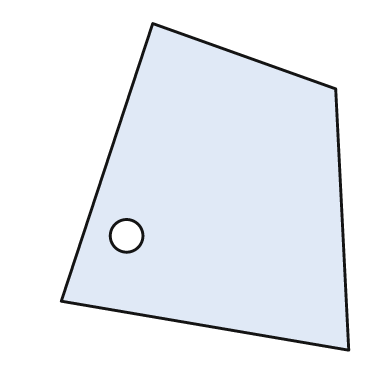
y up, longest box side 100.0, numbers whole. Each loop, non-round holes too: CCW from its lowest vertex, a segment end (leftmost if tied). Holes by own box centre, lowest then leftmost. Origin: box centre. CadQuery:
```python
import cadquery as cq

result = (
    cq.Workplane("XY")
    .moveTo(44.0, -50.0)
    .lineTo(40.0, 30.0)
    .lineTo(-16.0, 50.0)
    .lineTo(-44.0, -35.0)
    .close()
    .moveTo(-24.0, -15.0)
    .circle(5.0)
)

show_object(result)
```